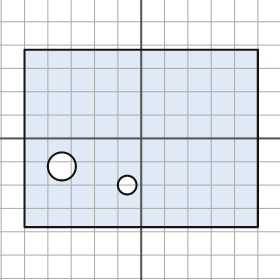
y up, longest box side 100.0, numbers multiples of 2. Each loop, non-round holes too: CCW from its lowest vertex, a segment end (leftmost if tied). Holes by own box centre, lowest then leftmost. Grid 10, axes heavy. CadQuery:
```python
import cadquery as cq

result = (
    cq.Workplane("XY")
    .moveTo(-50.0, -38.0)
    .lineTo(50.0, -38.0)
    .lineTo(50.0, 38.0)
    .lineTo(-50.0, 38.0)
    .close()
    .moveTo(-6.0, -20.0)
    .circle(4.0)
    .moveTo(-34.0, -12.0)
    .circle(6.0)
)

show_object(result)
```